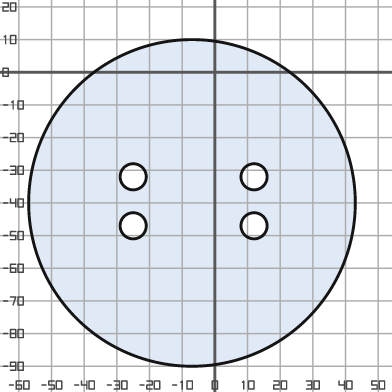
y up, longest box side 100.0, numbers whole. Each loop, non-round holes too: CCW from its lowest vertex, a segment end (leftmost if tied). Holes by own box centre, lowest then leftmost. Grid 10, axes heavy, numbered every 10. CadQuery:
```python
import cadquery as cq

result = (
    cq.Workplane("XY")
    .moveTo(-7.0, -40.0)
    .circle(50.0)
    .moveTo(-25.0, -47.0)
    .circle(4.0)
    .moveTo(12.0, -47.0)
    .circle(4.0)
    .moveTo(-25.0, -32.0)
    .circle(4.0)
    .moveTo(12.0, -32.0)
    .circle(4.0)
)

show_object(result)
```